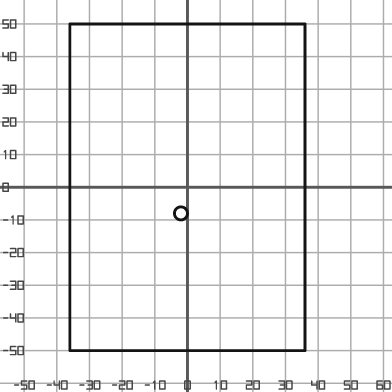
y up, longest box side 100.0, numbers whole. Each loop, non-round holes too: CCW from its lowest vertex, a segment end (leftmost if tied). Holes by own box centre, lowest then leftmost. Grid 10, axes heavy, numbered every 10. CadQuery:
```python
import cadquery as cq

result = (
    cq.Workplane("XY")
    .moveTo(-36.0, -50.0)
    .lineTo(36.0, -50.0)
    .lineTo(36.0, 50.0)
    .lineTo(-36.0, 50.0)
    .close()
    .moveTo(-2.0, -8.0)
    .circle(2.0)
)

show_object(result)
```